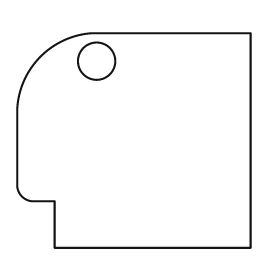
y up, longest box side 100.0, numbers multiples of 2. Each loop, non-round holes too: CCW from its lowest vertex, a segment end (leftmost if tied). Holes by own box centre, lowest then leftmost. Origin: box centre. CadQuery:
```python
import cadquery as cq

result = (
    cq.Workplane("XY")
    .moveTo(-34.0, -46.0)
    .lineTo(50.0, -46.0)
    .lineTo(50.0, 46.0)
    .lineTo(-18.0, 46.0)
    .threePointArc((-40.0, 36.0), (-50.0, 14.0))
    .lineTo(-50.0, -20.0)
    .threePointArc((-48.0, -24.0), (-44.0, -26.0))
    .lineTo(-34.0, -26.0)
    .close()
    .moveTo(-16.0, 34.0)
    .circle(8.0)
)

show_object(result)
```